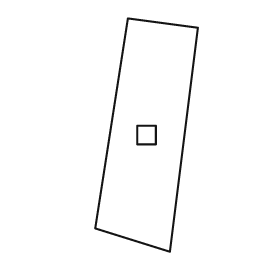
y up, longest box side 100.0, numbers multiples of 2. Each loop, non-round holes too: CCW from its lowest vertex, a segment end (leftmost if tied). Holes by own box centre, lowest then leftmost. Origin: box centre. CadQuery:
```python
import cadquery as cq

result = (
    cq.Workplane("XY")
    .moveTo(10.0, -50.0)
    .lineTo(22.0, 46.0)
    .lineTo(-8.0, 50.0)
    .lineTo(-22.0, -40.0)
    .close()
    .moveTo(-4.0, -4.0)
    .lineTo(4.0, -4.0)
    .lineTo(4.0, 4.0)
    .lineTo(-4.0, 4.0)
    .close()
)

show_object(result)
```